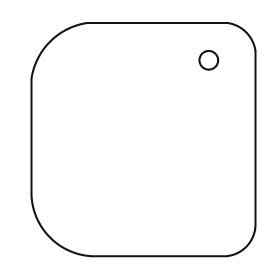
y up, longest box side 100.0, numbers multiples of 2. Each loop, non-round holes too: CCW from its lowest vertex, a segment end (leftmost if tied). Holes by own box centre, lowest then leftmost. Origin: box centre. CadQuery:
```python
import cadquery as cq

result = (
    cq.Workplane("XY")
    .moveTo(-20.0, -50.0)
    .lineTo(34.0, -50.0)
    .threePointArc((44.0, -46.0), (48.0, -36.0))
    .lineTo(48.0, 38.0)
    .threePointArc((44.0, 46.0), (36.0, 50.0))
    .lineTo(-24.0, 50.0)
    .threePointArc((-40.0, 42.0), (-48.0, 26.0))
    .lineTo(-48.0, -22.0)
    .threePointArc((-40.0, -42.0), (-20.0, -50.0))
    .close()
    .moveTo(28.0, 34.0)
    .circle(4.0)
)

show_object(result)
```